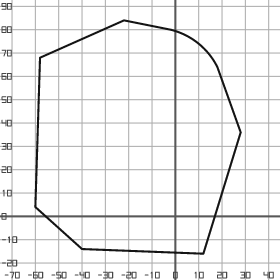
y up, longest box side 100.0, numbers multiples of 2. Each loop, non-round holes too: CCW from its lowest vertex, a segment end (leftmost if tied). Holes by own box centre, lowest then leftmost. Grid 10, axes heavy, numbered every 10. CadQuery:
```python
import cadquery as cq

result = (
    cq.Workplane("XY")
    .moveTo(12.0, -16.0)
    .lineTo(28.0, 36.0)
    .lineTo(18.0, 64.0)
    .threePointArc((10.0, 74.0), (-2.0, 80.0))
    .lineTo(-22.0, 84.0)
    .lineTo(-58.0, 68.0)
    .lineTo(-60.0, 4.0)
    .lineTo(-40.0, -14.0)
    .close()
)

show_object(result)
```